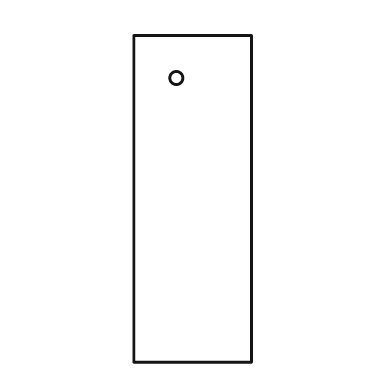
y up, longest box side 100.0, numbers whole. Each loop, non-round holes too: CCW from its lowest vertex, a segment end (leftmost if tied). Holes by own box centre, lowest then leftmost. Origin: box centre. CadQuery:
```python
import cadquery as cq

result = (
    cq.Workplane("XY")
    .moveTo(-18.0, -50.0)
    .lineTo(18.0, -50.0)
    .lineTo(18.0, 50.0)
    .lineTo(-18.0, 50.0)
    .close()
    .moveTo(-5.0, 37.0)
    .circle(2.0)
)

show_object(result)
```